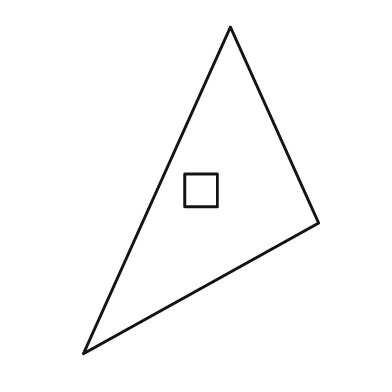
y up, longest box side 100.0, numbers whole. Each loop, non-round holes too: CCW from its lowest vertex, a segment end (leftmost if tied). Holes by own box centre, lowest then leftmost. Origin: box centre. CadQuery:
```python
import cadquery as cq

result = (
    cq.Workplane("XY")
    .moveTo(-36.0, -50.0)
    .lineTo(36.0, -10.0)
    .lineTo(9.0, 50.0)
    .close()
    .moveTo(-5.0, -5.0)
    .lineTo(5.0, -5.0)
    .lineTo(5.0, 5.0)
    .lineTo(-5.0, 5.0)
    .close()
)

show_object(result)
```